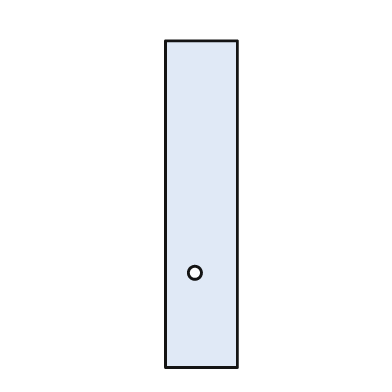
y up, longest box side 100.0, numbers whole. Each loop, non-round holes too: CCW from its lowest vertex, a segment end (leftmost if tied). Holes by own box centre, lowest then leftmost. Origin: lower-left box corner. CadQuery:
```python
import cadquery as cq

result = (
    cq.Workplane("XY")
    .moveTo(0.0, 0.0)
    .lineTo(22.0, 0.0)
    .lineTo(22.0, 100.0)
    .lineTo(0.0, 100.0)
    .close()
    .moveTo(9.0, 29.0)
    .circle(2.0)
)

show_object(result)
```